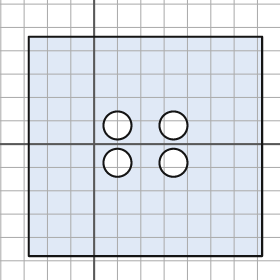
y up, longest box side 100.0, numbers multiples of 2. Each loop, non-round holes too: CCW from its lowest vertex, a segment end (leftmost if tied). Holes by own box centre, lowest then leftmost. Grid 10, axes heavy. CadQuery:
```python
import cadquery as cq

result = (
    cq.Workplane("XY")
    .moveTo(-28.0, -48.0)
    .lineTo(72.0, -48.0)
    .lineTo(72.0, 46.0)
    .lineTo(-28.0, 46.0)
    .close()
    .moveTo(10.0, -8.0)
    .circle(6.0)
    .moveTo(34.0, -8.0)
    .circle(6.0)
    .moveTo(10.0, 8.0)
    .circle(6.0)
    .moveTo(34.0, 8.0)
    .circle(6.0)
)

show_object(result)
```